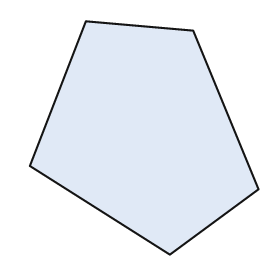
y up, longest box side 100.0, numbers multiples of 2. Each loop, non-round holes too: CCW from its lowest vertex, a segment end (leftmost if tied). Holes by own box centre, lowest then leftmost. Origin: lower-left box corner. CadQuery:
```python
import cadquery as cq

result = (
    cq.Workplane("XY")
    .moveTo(60.0, 0.0)
    .lineTo(98.0, 28.0)
    .lineTo(70.0, 96.0)
    .lineTo(24.0, 100.0)
    .lineTo(0.0, 38.0)
    .close()
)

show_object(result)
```